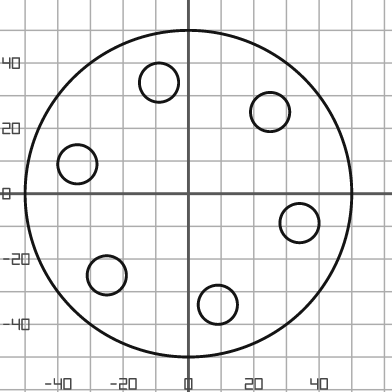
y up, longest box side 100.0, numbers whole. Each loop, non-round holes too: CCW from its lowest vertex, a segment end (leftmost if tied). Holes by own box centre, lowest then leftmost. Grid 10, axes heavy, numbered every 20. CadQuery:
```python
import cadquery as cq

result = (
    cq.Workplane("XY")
    .moveTo(0.0, 0.0)
    .circle(50.0)
    .moveTo(9.0, -34.0)
    .circle(6.0)
    .moveTo(-25.0, -25.0)
    .circle(6.0)
    .moveTo(34.0, -9.0)
    .circle(6.0)
    .moveTo(-34.0, 9.0)
    .circle(6.0)
    .moveTo(25.0, 25.0)
    .circle(6.0)
    .moveTo(-9.0, 34.0)
    .circle(6.0)
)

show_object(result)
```